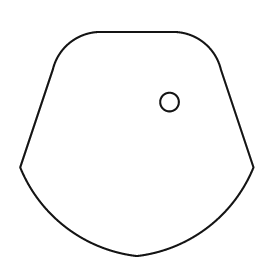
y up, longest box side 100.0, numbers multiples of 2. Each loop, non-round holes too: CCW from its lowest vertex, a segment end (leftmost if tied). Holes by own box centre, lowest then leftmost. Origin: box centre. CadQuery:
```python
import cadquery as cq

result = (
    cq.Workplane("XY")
    .moveTo(0.0, -48.0)
    .threePointArc((30.0, -36.0), (50.0, -10.0))
    .lineTo(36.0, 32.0)
    .threePointArc((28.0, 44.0), (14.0, 48.0))
    .lineTo(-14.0, 48.0)
    .threePointArc((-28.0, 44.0), (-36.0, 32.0))
    .lineTo(-50.0, -10.0)
    .threePointArc((-30.0, -36.0), (0.0, -48.0))
    .close()
    .moveTo(14.0, 18.0)
    .circle(4.0)
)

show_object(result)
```